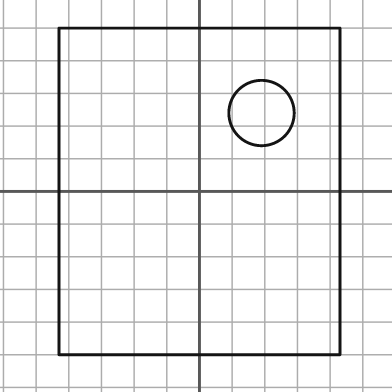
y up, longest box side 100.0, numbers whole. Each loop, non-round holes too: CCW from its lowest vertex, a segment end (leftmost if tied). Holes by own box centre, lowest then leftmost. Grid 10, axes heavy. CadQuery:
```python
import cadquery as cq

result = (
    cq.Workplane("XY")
    .moveTo(-43.0, -50.0)
    .lineTo(43.0, -50.0)
    .lineTo(43.0, 50.0)
    .lineTo(-43.0, 50.0)
    .close()
    .moveTo(19.0, 24.0)
    .circle(10.0)
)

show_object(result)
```